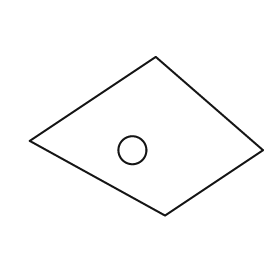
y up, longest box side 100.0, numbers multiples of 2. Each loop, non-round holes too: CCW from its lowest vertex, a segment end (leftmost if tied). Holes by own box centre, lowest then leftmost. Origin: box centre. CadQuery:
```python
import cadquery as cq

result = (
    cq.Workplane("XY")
    .moveTo(8.0, -34.0)
    .lineTo(50.0, -6.0)
    .lineTo(4.0, 34.0)
    .lineTo(-50.0, -2.0)
    .close()
    .moveTo(-6.0, -6.0)
    .circle(6.0)
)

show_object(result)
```